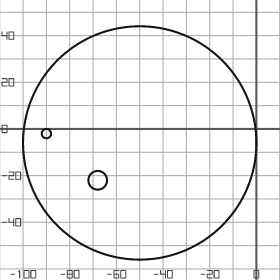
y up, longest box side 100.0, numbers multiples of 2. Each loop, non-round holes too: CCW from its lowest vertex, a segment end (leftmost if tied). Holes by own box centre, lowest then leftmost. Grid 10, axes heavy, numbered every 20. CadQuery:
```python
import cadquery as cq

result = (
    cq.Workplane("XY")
    .moveTo(-50.0, -6.0)
    .circle(50.0)
    .moveTo(-68.0, -22.0)
    .circle(4.0)
    .moveTo(-90.0, -2.0)
    .circle(2.0)
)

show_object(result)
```